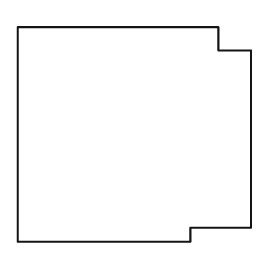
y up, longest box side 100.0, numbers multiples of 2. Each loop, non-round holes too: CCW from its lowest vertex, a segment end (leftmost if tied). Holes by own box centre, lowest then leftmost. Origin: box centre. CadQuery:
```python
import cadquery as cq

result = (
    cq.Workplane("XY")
    .moveTo(-50.0, -46.0)
    .lineTo(24.0, -46.0)
    .lineTo(24.0, -40.0)
    .lineTo(50.0, -40.0)
    .lineTo(50.0, 36.0)
    .lineTo(36.0, 36.0)
    .lineTo(36.0, 46.0)
    .lineTo(-50.0, 46.0)
    .close()
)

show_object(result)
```